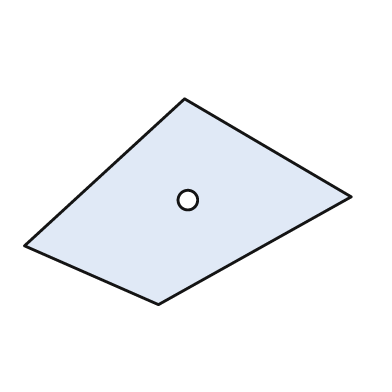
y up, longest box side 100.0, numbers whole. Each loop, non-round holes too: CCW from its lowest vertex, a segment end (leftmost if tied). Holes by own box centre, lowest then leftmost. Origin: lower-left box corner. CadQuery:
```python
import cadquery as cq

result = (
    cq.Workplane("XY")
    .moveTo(41.0, 0.0)
    .lineTo(100.0, 33.0)
    .lineTo(49.0, 63.0)
    .lineTo(0.0, 18.0)
    .close()
    .moveTo(50.0, 32.0)
    .circle(3.0)
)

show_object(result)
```